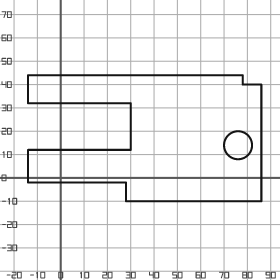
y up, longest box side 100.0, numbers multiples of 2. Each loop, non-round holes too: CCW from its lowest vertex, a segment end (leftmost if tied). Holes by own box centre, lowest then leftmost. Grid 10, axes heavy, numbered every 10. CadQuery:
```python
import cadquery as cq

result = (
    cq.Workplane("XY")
    .moveTo(28.0, -10.0)
    .lineTo(86.0, -10.0)
    .lineTo(86.0, 40.0)
    .lineTo(78.0, 40.0)
    .lineTo(78.0, 44.0)
    .lineTo(-14.0, 44.0)
    .lineTo(-14.0, 32.0)
    .lineTo(30.0, 32.0)
    .lineTo(30.0, 12.0)
    .lineTo(-14.0, 12.0)
    .lineTo(-14.0, -2.0)
    .lineTo(28.0, -2.0)
    .close()
    .moveTo(76.0, 14.0)
    .circle(6.0)
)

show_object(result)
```